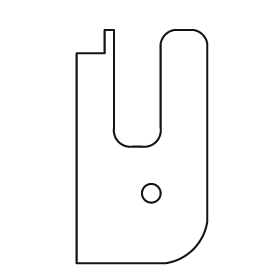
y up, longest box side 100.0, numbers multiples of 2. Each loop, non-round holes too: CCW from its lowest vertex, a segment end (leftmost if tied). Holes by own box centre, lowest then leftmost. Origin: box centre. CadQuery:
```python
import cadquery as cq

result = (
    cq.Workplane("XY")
    .moveTo(-28.0, -50.0)
    .lineTo(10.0, -50.0)
    .threePointArc((22.0, -44.0), (28.0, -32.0))
    .lineTo(28.0, 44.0)
    .threePointArc((26.0, 48.0), (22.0, 50.0))
    .lineTo(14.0, 50.0)
    .threePointArc((10.0, 48.0), (8.0, 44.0))
    .lineTo(8.0, 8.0)
    .threePointArc((6.0, 2.0), (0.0, 0.0))
    .lineTo(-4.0, 0.0)
    .threePointArc((-10.0, 2.0), (-12.0, 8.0))
    .lineTo(-12.0, 50.0)
    .lineTo(-16.0, 50.0)
    .lineTo(-16.0, 40.0)
    .lineTo(-28.0, 40.0)
    .close()
    .moveTo(4.0, -20.0)
    .circle(4.0)
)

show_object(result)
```